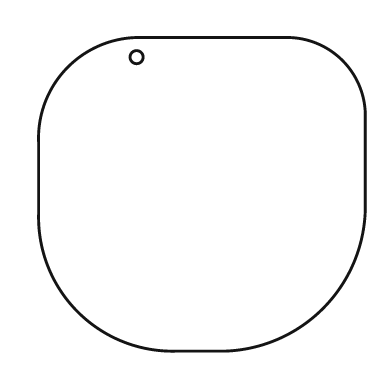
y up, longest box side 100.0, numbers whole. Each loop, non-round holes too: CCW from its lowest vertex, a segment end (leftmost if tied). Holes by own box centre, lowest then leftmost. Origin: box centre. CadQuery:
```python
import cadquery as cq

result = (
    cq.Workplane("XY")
    .moveTo(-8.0, -48.0)
    .lineTo(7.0, -48.0)
    .threePointArc((37.0, -35.0), (50.0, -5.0))
    .lineTo(50.0, 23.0)
    .threePointArc((43.0, 41.0), (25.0, 48.0))
    .lineTo(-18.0, 48.0)
    .threePointArc((-41.0, 39.0), (-50.0, 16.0))
    .lineTo(-50.0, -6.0)
    .threePointArc((-38.0, -36.0), (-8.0, -48.0))
    .close()
    .moveTo(-20.0, 42.0)
    .circle(2.0)
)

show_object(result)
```